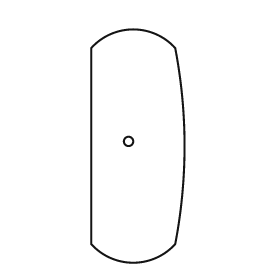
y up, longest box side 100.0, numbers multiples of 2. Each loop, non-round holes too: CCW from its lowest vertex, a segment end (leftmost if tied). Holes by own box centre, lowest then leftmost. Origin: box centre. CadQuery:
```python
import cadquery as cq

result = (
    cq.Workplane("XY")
    .moveTo(-20.0, -42.0)
    .threePointArc((-2.0, -50.0), (16.0, -42.0))
    .threePointArc((20.0, 0.0), (16.0, 42.0))
    .threePointArc((-2.0, 50.0), (-20.0, 42.0))
    .close()
    .moveTo(-4.0, 2.0)
    .circle(2.0)
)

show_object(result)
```